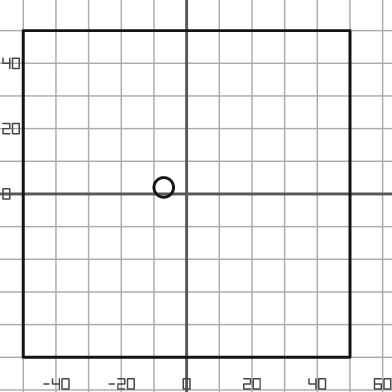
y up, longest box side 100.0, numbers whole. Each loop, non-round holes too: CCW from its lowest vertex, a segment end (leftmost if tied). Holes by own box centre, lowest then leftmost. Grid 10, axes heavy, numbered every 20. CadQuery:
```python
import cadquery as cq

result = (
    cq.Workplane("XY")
    .moveTo(-50.0, -50.0)
    .lineTo(50.0, -50.0)
    .lineTo(50.0, 50.0)
    .lineTo(-50.0, 50.0)
    .close()
    .moveTo(-7.0, 2.0)
    .circle(3.0)
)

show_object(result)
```